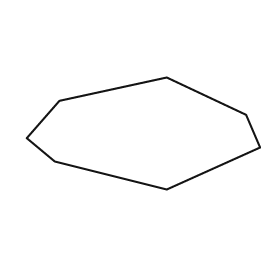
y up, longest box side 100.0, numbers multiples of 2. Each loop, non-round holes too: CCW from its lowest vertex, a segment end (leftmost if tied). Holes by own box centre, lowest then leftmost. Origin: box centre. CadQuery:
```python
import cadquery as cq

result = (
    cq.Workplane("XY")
    .moveTo(10.0, -24.0)
    .lineTo(50.0, -6.0)
    .lineTo(44.0, 8.0)
    .lineTo(10.0, 24.0)
    .lineTo(-36.0, 14.0)
    .lineTo(-50.0, -2.0)
    .lineTo(-38.0, -12.0)
    .close()
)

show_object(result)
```